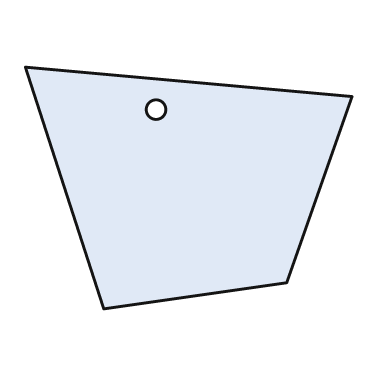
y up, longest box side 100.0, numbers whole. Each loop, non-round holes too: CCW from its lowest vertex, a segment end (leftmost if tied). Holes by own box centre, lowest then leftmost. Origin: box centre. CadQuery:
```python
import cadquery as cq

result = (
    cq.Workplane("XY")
    .moveTo(-26.0, -37.0)
    .lineTo(30.0, -29.0)
    .lineTo(50.0, 28.0)
    .lineTo(-50.0, 37.0)
    .close()
    .moveTo(-10.0, 24.0)
    .circle(3.0)
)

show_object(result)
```